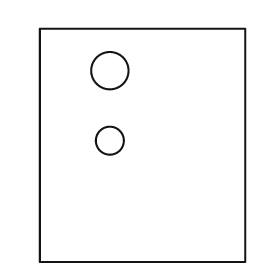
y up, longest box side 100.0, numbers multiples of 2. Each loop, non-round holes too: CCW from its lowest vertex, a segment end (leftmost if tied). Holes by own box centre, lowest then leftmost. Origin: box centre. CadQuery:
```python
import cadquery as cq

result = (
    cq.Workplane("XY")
    .moveTo(-44.0, -50.0)
    .lineTo(44.0, -50.0)
    .lineTo(44.0, 50.0)
    .lineTo(-44.0, 50.0)
    .close()
    .moveTo(-14.0, 2.0)
    .circle(6.0)
    .moveTo(-14.0, 32.0)
    .circle(8.0)
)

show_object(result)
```